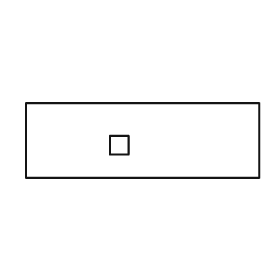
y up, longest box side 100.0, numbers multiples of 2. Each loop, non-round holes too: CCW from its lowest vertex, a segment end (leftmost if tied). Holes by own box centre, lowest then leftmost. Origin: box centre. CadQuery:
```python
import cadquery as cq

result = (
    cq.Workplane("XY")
    .moveTo(-50.0, -16.0)
    .lineTo(50.0, -16.0)
    .lineTo(50.0, 16.0)
    .lineTo(-50.0, 16.0)
    .close()
    .moveTo(-14.0, -6.0)
    .lineTo(-6.0, -6.0)
    .lineTo(-6.0, 2.0)
    .lineTo(-14.0, 2.0)
    .close()
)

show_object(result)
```